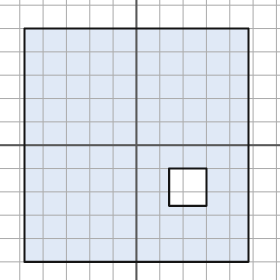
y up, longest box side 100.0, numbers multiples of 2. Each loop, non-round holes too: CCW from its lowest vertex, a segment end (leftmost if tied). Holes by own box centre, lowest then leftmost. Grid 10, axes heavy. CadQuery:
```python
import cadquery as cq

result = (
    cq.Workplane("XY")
    .moveTo(-48.0, -50.0)
    .lineTo(48.0, -50.0)
    .lineTo(48.0, 50.0)
    .lineTo(-48.0, 50.0)
    .close()
    .moveTo(14.0, -26.0)
    .lineTo(30.0, -26.0)
    .lineTo(30.0, -10.0)
    .lineTo(14.0, -10.0)
    .close()
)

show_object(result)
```